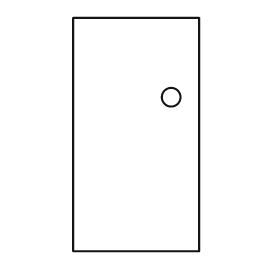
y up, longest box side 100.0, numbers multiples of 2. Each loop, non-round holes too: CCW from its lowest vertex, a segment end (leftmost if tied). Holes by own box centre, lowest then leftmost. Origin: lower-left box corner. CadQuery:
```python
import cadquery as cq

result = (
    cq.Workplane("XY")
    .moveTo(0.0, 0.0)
    .lineTo(54.0, 0.0)
    .lineTo(54.0, 100.0)
    .lineTo(0.0, 100.0)
    .close()
    .moveTo(42.0, 66.0)
    .circle(4.0)
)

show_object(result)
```